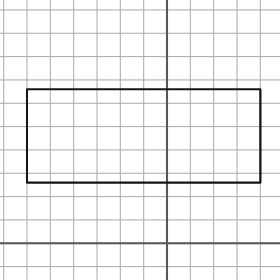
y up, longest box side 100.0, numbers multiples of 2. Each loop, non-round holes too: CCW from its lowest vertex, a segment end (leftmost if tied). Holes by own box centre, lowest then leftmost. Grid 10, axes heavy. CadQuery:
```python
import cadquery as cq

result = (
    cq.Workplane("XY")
    .moveTo(-60.0, 26.0)
    .lineTo(40.0, 26.0)
    .lineTo(40.0, 66.0)
    .lineTo(-60.0, 66.0)
    .close()
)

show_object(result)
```